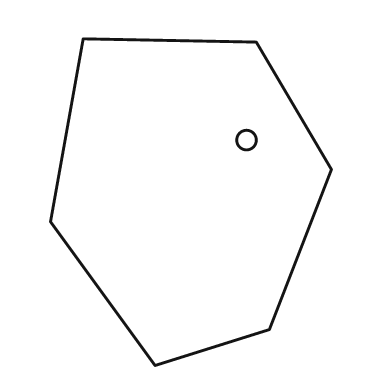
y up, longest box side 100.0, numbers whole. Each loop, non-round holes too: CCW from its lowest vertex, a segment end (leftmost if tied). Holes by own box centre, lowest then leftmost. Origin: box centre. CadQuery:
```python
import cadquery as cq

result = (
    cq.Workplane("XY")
    .moveTo(-11.0, -50.0)
    .lineTo(24.0, -39.0)
    .lineTo(43.0, 10.0)
    .lineTo(20.0, 49.0)
    .lineTo(-33.0, 50.0)
    .lineTo(-43.0, -6.0)
    .close()
    .moveTo(17.0, 19.0)
    .circle(3.0)
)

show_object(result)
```